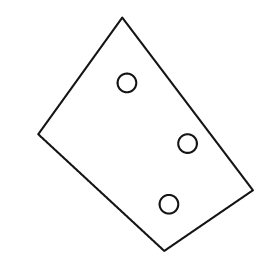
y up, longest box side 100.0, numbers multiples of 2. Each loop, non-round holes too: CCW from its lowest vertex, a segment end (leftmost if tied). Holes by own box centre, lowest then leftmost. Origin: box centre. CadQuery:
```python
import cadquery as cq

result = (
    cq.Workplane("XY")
    .moveTo(8.0, -50.0)
    .lineTo(46.0, -24.0)
    .lineTo(-10.0, 50.0)
    .lineTo(-46.0, 0.0)
    .close()
    .moveTo(10.0, -30.0)
    .circle(4.0)
    .moveTo(18.0, -4.0)
    .circle(4.0)
    .moveTo(-8.0, 22.0)
    .circle(4.0)
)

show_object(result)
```